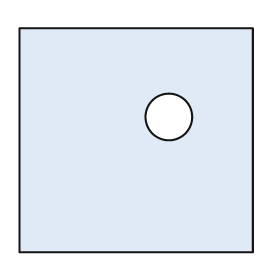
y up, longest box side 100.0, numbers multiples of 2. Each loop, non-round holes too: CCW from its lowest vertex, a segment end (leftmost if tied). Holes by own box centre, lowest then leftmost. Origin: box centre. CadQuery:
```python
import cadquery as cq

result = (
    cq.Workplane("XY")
    .moveTo(-50.0, -48.0)
    .lineTo(50.0, -48.0)
    .lineTo(50.0, 48.0)
    .lineTo(-50.0, 48.0)
    .close()
    .moveTo(14.0, 10.0)
    .circle(10.0)
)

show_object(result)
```